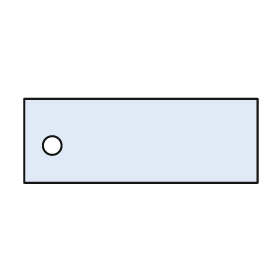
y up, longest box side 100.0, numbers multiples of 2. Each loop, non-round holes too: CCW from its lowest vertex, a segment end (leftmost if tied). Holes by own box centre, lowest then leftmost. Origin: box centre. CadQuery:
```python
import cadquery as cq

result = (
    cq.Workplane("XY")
    .moveTo(-50.0, -18.0)
    .lineTo(50.0, -18.0)
    .lineTo(50.0, 18.0)
    .lineTo(-50.0, 18.0)
    .close()
    .moveTo(-38.0, -2.0)
    .circle(4.0)
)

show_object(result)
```